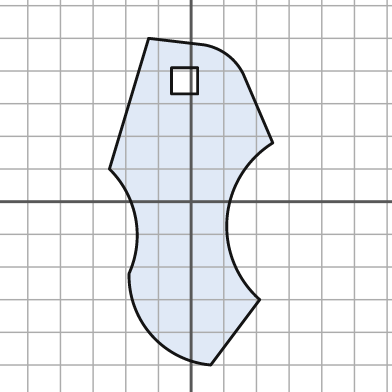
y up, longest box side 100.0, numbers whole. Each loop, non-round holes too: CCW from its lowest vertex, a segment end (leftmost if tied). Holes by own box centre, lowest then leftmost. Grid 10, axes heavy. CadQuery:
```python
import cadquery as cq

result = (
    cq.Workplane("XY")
    .moveTo(6.0, -50.0)
    .lineTo(21.0, -30.0)
    .threePointArc((11.0, -5.0), (25.0, 18.0))
    .lineTo(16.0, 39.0)
    .threePointArc((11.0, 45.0), (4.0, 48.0))
    .lineTo(-13.0, 50.0)
    .lineTo(-25.0, 10.0)
    .threePointArc((-17.0, -5.0), (-19.0, -22.0))
    .threePointArc((-12.0, -41.0), (6.0, -50.0))
    .close()
    .moveTo(-6.0, 33.0)
    .lineTo(2.0, 33.0)
    .lineTo(2.0, 41.0)
    .lineTo(-6.0, 41.0)
    .close()
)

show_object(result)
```